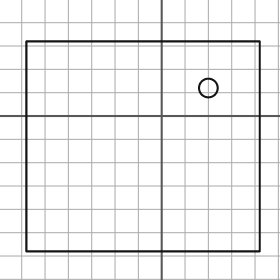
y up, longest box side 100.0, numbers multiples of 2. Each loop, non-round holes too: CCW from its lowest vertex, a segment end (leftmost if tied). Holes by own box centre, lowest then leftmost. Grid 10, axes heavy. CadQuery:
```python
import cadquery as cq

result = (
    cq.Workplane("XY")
    .moveTo(-58.0, -58.0)
    .lineTo(42.0, -58.0)
    .lineTo(42.0, 32.0)
    .lineTo(-58.0, 32.0)
    .close()
    .moveTo(20.0, 12.0)
    .circle(4.0)
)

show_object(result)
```